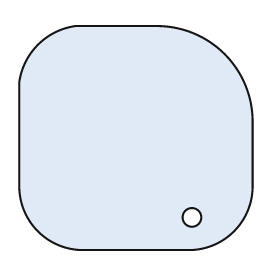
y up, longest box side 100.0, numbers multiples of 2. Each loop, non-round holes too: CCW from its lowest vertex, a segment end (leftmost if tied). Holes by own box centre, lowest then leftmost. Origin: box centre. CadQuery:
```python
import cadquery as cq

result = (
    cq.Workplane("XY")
    .moveTo(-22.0, -48.0)
    .lineTo(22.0, -48.0)
    .threePointArc((42.0, -40.0), (50.0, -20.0))
    .lineTo(50.0, 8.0)
    .threePointArc((38.0, 36.0), (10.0, 48.0))
    .lineTo(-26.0, 48.0)
    .threePointArc((-42.0, 40.0), (-50.0, 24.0))
    .lineTo(-50.0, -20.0)
    .threePointArc((-42.0, -40.0), (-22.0, -48.0))
    .close()
    .moveTo(24.0, -34.0)
    .circle(4.0)
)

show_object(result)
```